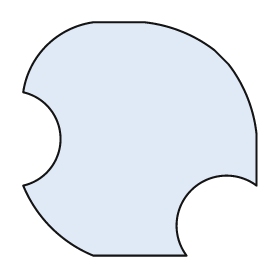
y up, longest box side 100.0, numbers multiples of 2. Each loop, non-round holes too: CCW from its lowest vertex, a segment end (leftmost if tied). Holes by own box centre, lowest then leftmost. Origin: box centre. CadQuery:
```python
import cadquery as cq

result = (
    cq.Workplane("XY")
    .moveTo(-20.0, -50.0)
    .lineTo(20.0, -50.0)
    .threePointArc((22.0, -22.0), (50.0, -20.0))
    .lineTo(50.0, 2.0)
    .threePointArc((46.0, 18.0), (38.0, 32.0))
    .lineTo(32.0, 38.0)
    .threePointArc((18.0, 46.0), (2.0, 50.0))
    .lineTo(-20.0, 50.0)
    .threePointArc((-40.0, 40.0), (-50.0, 20.0))
    .threePointArc((-34.0, 0.0), (-50.0, -20.0))
    .threePointArc((-38.0, -38.0), (-20.0, -50.0))
    .close()
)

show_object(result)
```